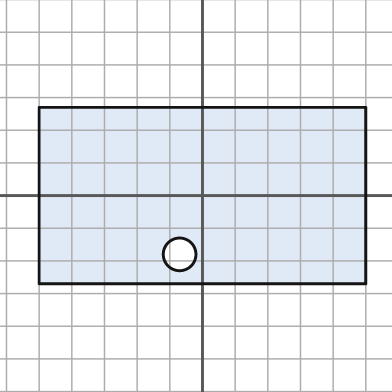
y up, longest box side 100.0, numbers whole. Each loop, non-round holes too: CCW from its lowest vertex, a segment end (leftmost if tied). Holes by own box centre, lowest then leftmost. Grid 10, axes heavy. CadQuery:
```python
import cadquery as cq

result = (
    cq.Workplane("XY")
    .moveTo(-50.0, -27.0)
    .lineTo(50.0, -27.0)
    .lineTo(50.0, 27.0)
    .lineTo(-50.0, 27.0)
    .close()
    .moveTo(-7.0, -18.0)
    .circle(5.0)
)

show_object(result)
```